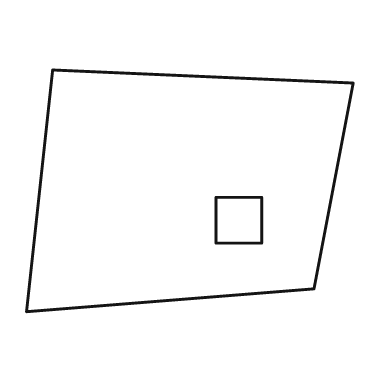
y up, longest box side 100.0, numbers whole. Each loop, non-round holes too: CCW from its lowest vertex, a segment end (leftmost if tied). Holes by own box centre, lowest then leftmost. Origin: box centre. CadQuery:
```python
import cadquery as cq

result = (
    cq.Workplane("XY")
    .moveTo(-50.0, -37.0)
    .lineTo(38.0, -30.0)
    .lineTo(50.0, 33.0)
    .lineTo(-42.0, 37.0)
    .close()
    .moveTo(8.0, -16.0)
    .lineTo(22.0, -16.0)
    .lineTo(22.0, -2.0)
    .lineTo(8.0, -2.0)
    .close()
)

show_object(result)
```